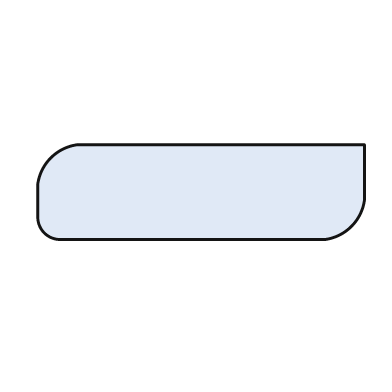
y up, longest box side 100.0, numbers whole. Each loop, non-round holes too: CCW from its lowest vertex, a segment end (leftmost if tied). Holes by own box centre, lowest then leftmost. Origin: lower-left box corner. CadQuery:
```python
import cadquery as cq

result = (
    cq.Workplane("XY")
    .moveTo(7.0, 0.0)
    .lineTo(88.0, 0.0)
    .threePointArc((96.0, 4.0), (100.0, 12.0))
    .lineTo(100.0, 29.0)
    .lineTo(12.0, 29.0)
    .threePointArc((4.0, 25.0), (0.0, 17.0))
    .lineTo(0.0, 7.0)
    .threePointArc((2.0, 2.0), (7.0, 0.0))
    .close()
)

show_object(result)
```